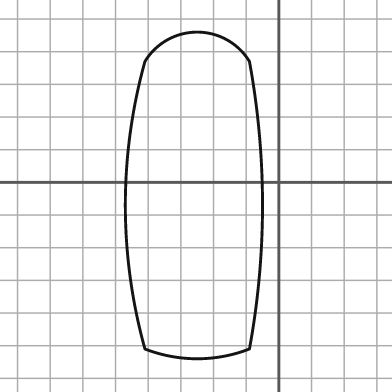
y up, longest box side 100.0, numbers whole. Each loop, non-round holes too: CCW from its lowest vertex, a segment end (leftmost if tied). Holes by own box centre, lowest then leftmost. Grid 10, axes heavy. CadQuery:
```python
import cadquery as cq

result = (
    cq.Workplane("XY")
    .moveTo(-41.0, -51.0)
    .threePointArc((-25.0, -54.0), (-9.0, -51.0))
    .threePointArc((-5.0, -7.0), (-9.0, 37.0))
    .threePointArc((-25.0, 46.0), (-41.0, 37.0))
    .threePointArc((-47.0, -7.0), (-41.0, -51.0))
    .close()
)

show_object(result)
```